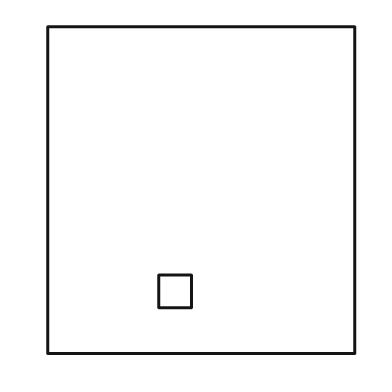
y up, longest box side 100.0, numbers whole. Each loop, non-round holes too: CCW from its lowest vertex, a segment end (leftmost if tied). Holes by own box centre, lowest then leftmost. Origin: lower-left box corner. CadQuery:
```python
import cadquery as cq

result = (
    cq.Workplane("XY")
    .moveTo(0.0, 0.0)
    .lineTo(94.0, 0.0)
    .lineTo(94.0, 100.0)
    .lineTo(0.0, 100.0)
    .close()
    .moveTo(34.0, 14.0)
    .lineTo(44.0, 14.0)
    .lineTo(44.0, 24.0)
    .lineTo(34.0, 24.0)
    .close()
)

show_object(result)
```